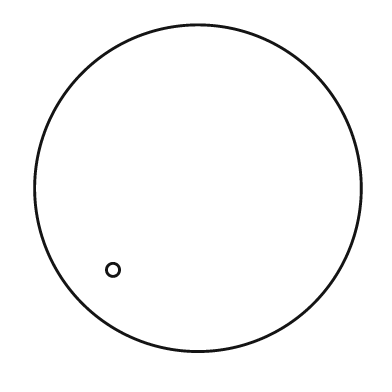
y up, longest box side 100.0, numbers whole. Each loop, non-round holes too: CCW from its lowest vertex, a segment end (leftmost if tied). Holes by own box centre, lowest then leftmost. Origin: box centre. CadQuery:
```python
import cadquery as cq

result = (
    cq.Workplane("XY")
    .moveTo(0.0, 0.0)
    .circle(50.0)
    .moveTo(-26.0, -25.0)
    .circle(2.0)
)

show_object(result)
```